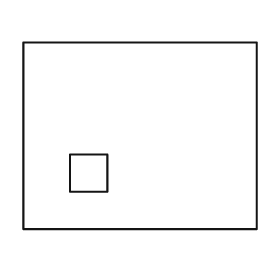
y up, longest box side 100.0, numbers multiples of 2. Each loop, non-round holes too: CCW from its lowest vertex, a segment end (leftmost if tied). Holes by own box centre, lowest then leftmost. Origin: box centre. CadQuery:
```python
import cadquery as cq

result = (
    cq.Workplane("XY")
    .moveTo(-50.0, -40.0)
    .lineTo(50.0, -40.0)
    .lineTo(50.0, 40.0)
    .lineTo(-50.0, 40.0)
    .close()
    .moveTo(-30.0, -24.0)
    .lineTo(-14.0, -24.0)
    .lineTo(-14.0, -8.0)
    .lineTo(-30.0, -8.0)
    .close()
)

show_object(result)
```